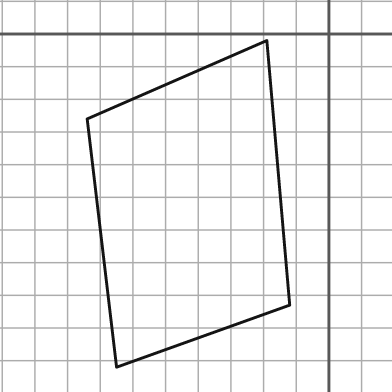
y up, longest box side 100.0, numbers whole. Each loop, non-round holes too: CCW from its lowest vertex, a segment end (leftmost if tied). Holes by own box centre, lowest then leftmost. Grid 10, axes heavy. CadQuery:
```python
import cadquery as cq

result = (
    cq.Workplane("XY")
    .moveTo(-65.0, -102.0)
    .lineTo(-12.0, -83.0)
    .lineTo(-19.0, -2.0)
    .lineTo(-74.0, -26.0)
    .close()
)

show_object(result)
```